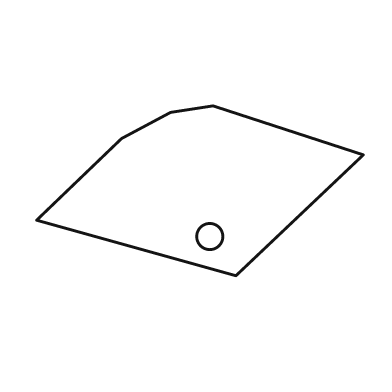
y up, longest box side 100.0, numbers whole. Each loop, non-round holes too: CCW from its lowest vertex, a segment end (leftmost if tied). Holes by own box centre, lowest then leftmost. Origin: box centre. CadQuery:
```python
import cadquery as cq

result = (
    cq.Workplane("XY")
    .moveTo(11.0, -26.0)
    .lineTo(50.0, 11.0)
    .lineTo(4.0, 26.0)
    .lineTo(-9.0, 24.0)
    .lineTo(-24.0, 16.0)
    .lineTo(-50.0, -9.0)
    .close()
    .moveTo(3.0, -14.0)
    .circle(4.0)
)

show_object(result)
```